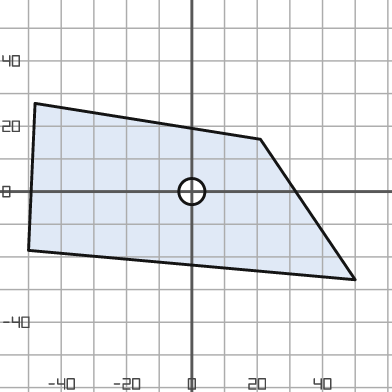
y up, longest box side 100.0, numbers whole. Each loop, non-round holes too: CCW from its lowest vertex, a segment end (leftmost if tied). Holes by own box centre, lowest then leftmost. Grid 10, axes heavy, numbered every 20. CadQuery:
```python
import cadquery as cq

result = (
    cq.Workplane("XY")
    .moveTo(50.0, -27.0)
    .lineTo(21.0, 16.0)
    .lineTo(-48.0, 27.0)
    .lineTo(-50.0, -18.0)
    .close()
    .moveTo(0.0, 0.0)
    .circle(4.0)
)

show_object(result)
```